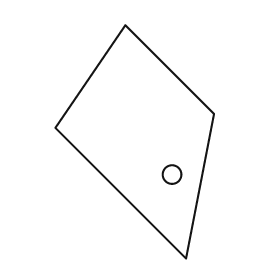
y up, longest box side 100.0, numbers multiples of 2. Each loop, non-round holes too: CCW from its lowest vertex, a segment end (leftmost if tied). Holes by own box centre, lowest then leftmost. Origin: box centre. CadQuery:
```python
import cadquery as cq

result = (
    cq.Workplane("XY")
    .moveTo(22.0, -50.0)
    .lineTo(34.0, 12.0)
    .lineTo(-4.0, 50.0)
    .lineTo(-34.0, 6.0)
    .close()
    .moveTo(16.0, -14.0)
    .circle(4.0)
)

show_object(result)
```